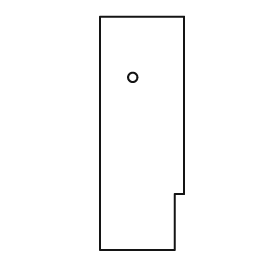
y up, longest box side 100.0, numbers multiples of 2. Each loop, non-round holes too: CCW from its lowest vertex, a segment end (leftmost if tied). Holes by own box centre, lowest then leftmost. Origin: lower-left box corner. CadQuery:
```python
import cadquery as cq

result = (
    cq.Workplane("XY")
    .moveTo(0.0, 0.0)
    .lineTo(32.0, 0.0)
    .lineTo(32.0, 24.0)
    .lineTo(36.0, 24.0)
    .lineTo(36.0, 100.0)
    .lineTo(0.0, 100.0)
    .close()
    .moveTo(14.0, 74.0)
    .circle(2.0)
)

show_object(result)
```